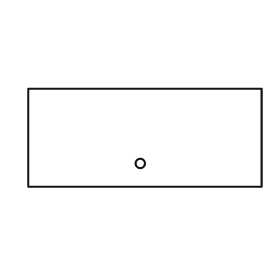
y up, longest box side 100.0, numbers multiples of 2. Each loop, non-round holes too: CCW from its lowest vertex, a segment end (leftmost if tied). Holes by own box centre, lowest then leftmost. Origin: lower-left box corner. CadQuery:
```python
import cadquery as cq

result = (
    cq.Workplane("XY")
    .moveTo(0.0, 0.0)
    .lineTo(100.0, 0.0)
    .lineTo(100.0, 42.0)
    .lineTo(0.0, 42.0)
    .close()
    .moveTo(48.0, 10.0)
    .circle(2.0)
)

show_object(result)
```